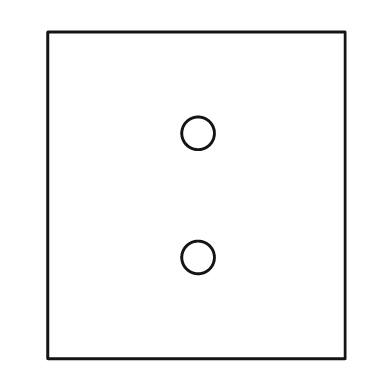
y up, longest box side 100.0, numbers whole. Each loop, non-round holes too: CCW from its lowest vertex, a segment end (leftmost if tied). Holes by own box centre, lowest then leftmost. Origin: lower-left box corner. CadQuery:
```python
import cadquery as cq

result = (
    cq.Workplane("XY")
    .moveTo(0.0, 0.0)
    .lineTo(91.0, 0.0)
    .lineTo(91.0, 100.0)
    .lineTo(0.0, 100.0)
    .close()
    .moveTo(46.0, 31.0)
    .circle(5.0)
    .moveTo(46.0, 69.0)
    .circle(5.0)
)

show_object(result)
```